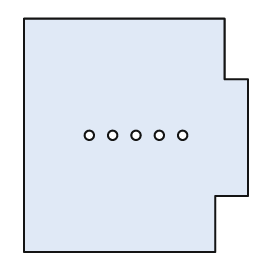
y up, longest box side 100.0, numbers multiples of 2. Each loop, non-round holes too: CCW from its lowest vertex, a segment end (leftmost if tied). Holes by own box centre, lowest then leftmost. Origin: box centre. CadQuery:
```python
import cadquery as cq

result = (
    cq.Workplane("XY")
    .moveTo(-48.0, -50.0)
    .lineTo(34.0, -50.0)
    .lineTo(34.0, -26.0)
    .lineTo(48.0, -26.0)
    .lineTo(48.0, 24.0)
    .lineTo(38.0, 24.0)
    .lineTo(38.0, 50.0)
    .lineTo(-48.0, 50.0)
    .close()
    .moveTo(-20.0, 0.0)
    .circle(2.0)
    .moveTo(-10.0, 0.0)
    .circle(2.0)
    .moveTo(0.0, 0.0)
    .circle(2.0)
    .moveTo(10.0, 0.0)
    .circle(2.0)
    .moveTo(20.0, 0.0)
    .circle(2.0)
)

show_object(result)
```